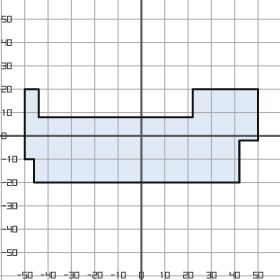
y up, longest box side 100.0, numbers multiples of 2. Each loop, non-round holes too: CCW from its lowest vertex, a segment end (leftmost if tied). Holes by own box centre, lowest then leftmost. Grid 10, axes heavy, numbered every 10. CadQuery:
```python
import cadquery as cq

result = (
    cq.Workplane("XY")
    .moveTo(-46.0, -20.0)
    .lineTo(42.0, -20.0)
    .lineTo(42.0, -2.0)
    .lineTo(50.0, -2.0)
    .lineTo(50.0, 20.0)
    .lineTo(22.0, 20.0)
    .lineTo(22.0, 8.0)
    .lineTo(-44.0, 8.0)
    .lineTo(-44.0, 20.0)
    .lineTo(-50.0, 20.0)
    .lineTo(-50.0, -10.0)
    .lineTo(-46.0, -10.0)
    .close()
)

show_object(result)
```